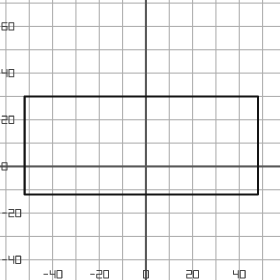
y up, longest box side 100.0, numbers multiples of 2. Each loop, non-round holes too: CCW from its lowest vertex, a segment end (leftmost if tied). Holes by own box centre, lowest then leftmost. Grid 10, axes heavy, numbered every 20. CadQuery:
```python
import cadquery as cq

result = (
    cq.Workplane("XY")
    .moveTo(-52.0, -12.0)
    .lineTo(48.0, -12.0)
    .lineTo(48.0, 30.0)
    .lineTo(-52.0, 30.0)
    .close()
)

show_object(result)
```